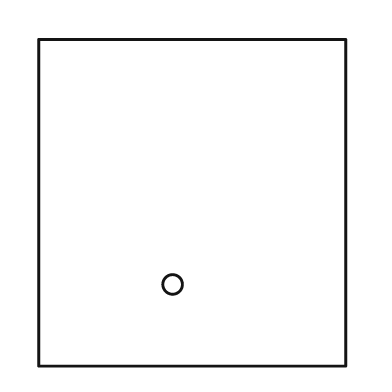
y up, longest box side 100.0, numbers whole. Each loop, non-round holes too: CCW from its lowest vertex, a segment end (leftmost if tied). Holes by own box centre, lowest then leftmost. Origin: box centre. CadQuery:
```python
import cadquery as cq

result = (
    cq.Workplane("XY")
    .moveTo(-47.0, -50.0)
    .lineTo(47.0, -50.0)
    .lineTo(47.0, 50.0)
    .lineTo(-47.0, 50.0)
    .close()
    .moveTo(-6.0, -25.0)
    .circle(3.0)
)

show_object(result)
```